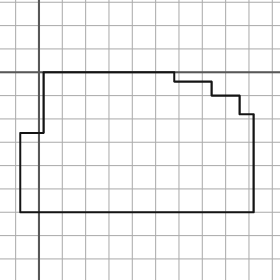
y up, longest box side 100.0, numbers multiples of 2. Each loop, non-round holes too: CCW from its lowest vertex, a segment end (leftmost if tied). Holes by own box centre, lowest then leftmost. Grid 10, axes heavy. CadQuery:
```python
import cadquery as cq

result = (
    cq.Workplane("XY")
    .moveTo(-8.0, -60.0)
    .lineTo(92.0, -60.0)
    .lineTo(92.0, -18.0)
    .lineTo(86.0, -18.0)
    .lineTo(86.0, -10.0)
    .lineTo(74.0, -10.0)
    .lineTo(74.0, -4.0)
    .lineTo(58.0, -4.0)
    .lineTo(58.0, 0.0)
    .lineTo(2.0, 0.0)
    .lineTo(2.0, -26.0)
    .lineTo(-8.0, -26.0)
    .close()
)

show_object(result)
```